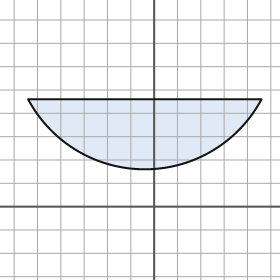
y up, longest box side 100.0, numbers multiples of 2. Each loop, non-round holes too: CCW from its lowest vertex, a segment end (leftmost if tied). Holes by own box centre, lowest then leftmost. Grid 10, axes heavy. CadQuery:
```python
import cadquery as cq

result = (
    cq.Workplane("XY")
    .moveTo(-54.0, 46.0)
    .threePointArc((-4.0, 16.0), (46.0, 46.0))
    .close()
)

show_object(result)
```